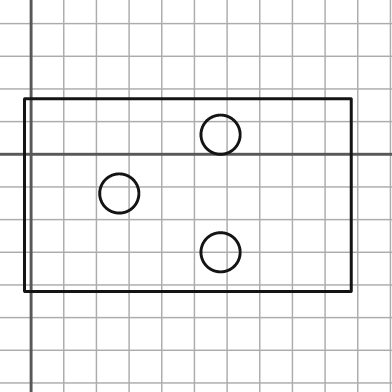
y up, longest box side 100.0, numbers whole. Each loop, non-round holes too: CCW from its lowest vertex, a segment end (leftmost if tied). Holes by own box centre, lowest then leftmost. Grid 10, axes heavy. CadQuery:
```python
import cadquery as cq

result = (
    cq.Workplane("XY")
    .moveTo(-2.0, -42.0)
    .lineTo(98.0, -42.0)
    .lineTo(98.0, 17.0)
    .lineTo(-2.0, 17.0)
    .close()
    .moveTo(58.0, -30.0)
    .circle(6.0)
    .moveTo(27.0, -12.0)
    .circle(6.0)
    .moveTo(58.0, 6.0)
    .circle(6.0)
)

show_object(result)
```